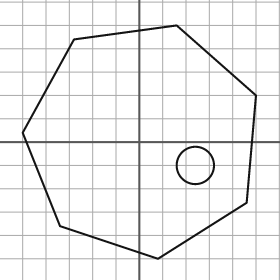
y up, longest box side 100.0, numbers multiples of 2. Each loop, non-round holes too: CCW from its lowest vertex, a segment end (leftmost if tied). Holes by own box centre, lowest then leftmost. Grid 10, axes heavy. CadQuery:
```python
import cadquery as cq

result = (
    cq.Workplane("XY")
    .moveTo(8.0, -50.0)
    .lineTo(46.0, -26.0)
    .lineTo(50.0, 20.0)
    .lineTo(16.0, 50.0)
    .lineTo(-28.0, 44.0)
    .lineTo(-50.0, 4.0)
    .lineTo(-34.0, -36.0)
    .close()
    .moveTo(24.0, -10.0)
    .circle(8.0)
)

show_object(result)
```